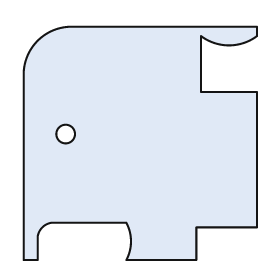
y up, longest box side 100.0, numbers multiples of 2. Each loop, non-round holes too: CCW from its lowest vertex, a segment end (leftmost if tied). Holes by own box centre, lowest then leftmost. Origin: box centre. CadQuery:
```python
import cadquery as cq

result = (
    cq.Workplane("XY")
    .moveTo(-50.0, -50.0)
    .lineTo(-44.0, -50.0)
    .lineTo(-44.0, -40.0)
    .threePointArc((-42.0, -36.0), (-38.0, -34.0))
    .lineTo(-6.0, -34.0)
    .threePointArc((-4.0, -42.0), (-6.0, -50.0))
    .lineTo(24.0, -50.0)
    .lineTo(24.0, -36.0)
    .lineTo(50.0, -36.0)
    .lineTo(50.0, 22.0)
    .lineTo(26.0, 22.0)
    .lineTo(26.0, 46.0)
    .threePointArc((38.0, 42.0), (50.0, 46.0))
    .lineTo(50.0, 50.0)
    .lineTo(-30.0, 50.0)
    .threePointArc((-44.0, 44.0), (-50.0, 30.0))
    .close()
    .moveTo(-32.0, 4.0)
    .circle(4.0)
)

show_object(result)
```